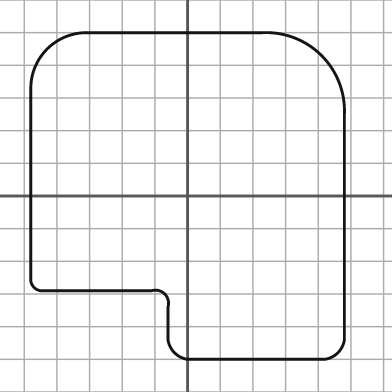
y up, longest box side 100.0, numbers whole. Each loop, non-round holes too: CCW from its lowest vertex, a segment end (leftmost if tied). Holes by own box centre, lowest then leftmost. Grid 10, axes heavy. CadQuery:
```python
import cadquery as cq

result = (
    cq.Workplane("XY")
    .moveTo(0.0, -50.0)
    .lineTo(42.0, -50.0)
    .threePointArc((46.0, -48.0), (48.0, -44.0))
    .lineTo(48.0, 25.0)
    .threePointArc((41.0, 43.0), (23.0, 50.0))
    .lineTo(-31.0, 50.0)
    .threePointArc((-43.0, 45.0), (-48.0, 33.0))
    .lineTo(-48.0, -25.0)
    .threePointArc((-47.0, -28.0), (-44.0, -29.0))
    .lineTo(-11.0, -29.0)
    .threePointArc((-7.0, -30.0), (-6.0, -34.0))
    .lineTo(-6.0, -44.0)
    .threePointArc((-4.0, -48.0), (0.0, -50.0))
    .close()
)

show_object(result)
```